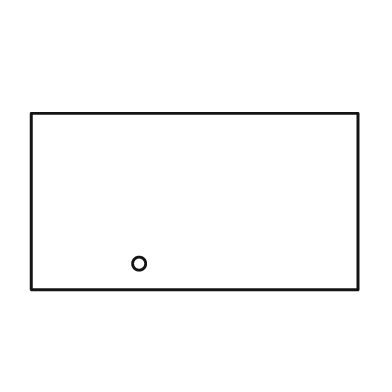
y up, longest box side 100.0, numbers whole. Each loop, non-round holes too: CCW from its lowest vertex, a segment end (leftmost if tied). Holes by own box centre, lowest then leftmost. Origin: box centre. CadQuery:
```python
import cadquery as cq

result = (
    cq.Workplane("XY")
    .moveTo(-50.0, -27.0)
    .lineTo(50.0, -27.0)
    .lineTo(50.0, 27.0)
    .lineTo(-50.0, 27.0)
    .close()
    .moveTo(-17.0, -19.0)
    .circle(2.0)
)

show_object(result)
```